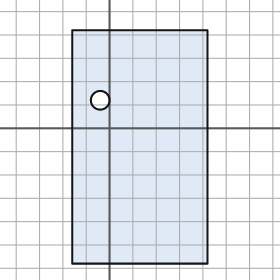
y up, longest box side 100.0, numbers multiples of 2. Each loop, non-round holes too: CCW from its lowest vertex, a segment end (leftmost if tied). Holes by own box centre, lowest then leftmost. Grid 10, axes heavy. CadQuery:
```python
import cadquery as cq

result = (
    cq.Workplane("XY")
    .moveTo(-16.0, -58.0)
    .lineTo(42.0, -58.0)
    .lineTo(42.0, 42.0)
    .lineTo(-16.0, 42.0)
    .close()
    .moveTo(-4.0, 12.0)
    .circle(4.0)
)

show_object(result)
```